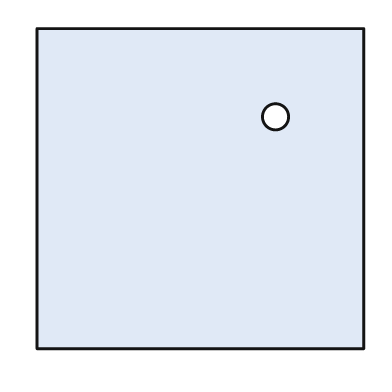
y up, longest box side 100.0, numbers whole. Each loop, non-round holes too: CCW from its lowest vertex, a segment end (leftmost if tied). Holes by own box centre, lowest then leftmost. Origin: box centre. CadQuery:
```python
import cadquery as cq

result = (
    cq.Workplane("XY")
    .moveTo(-50.0, -49.0)
    .lineTo(50.0, -49.0)
    .lineTo(50.0, 49.0)
    .lineTo(-50.0, 49.0)
    .close()
    .moveTo(23.0, 22.0)
    .circle(4.0)
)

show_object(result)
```